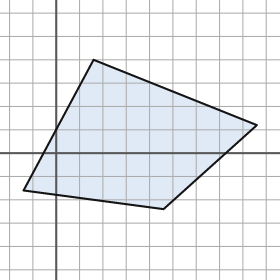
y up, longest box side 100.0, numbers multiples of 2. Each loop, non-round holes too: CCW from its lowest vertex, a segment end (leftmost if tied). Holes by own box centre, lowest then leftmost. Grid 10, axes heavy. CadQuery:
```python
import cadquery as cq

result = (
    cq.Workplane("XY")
    .moveTo(46.0, -24.0)
    .lineTo(86.0, 12.0)
    .lineTo(16.0, 40.0)
    .lineTo(-14.0, -16.0)
    .close()
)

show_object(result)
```